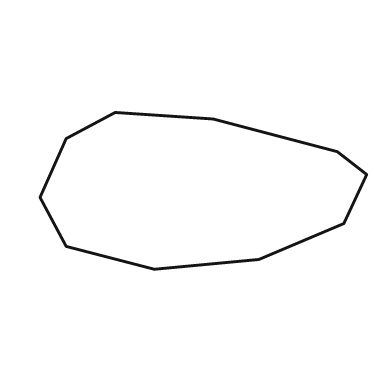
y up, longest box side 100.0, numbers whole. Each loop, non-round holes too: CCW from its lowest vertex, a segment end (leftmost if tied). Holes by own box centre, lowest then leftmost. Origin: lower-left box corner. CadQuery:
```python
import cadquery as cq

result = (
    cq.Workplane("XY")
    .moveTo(35.0, 0.0)
    .lineTo(67.0, 3.0)
    .lineTo(93.0, 14.0)
    .lineTo(100.0, 29.0)
    .lineTo(91.0, 36.0)
    .lineTo(53.0, 46.0)
    .lineTo(23.0, 48.0)
    .lineTo(8.0, 40.0)
    .lineTo(0.0, 22.0)
    .lineTo(8.0, 7.0)
    .close()
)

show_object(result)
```